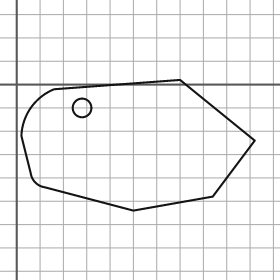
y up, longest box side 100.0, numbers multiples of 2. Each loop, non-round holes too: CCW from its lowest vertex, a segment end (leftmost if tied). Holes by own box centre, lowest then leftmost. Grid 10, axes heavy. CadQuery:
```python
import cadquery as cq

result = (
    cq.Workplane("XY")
    .moveTo(50.0, -54.0)
    .lineTo(84.0, -48.0)
    .lineTo(102.0, -24.0)
    .lineTo(70.0, 2.0)
    .lineTo(16.0, -2.0)
    .threePointArc((6.0, -10.0), (2.0, -22.0))
    .lineTo(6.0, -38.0)
    .threePointArc((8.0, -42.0), (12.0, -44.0))
    .close()
    .moveTo(28.0, -10.0)
    .circle(4.0)
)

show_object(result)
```